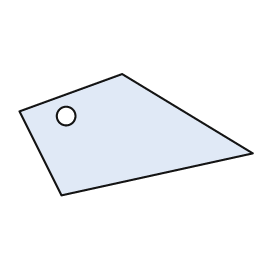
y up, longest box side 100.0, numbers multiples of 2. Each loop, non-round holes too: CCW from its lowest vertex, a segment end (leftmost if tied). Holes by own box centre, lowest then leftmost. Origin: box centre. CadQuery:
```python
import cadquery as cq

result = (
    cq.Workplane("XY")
    .moveTo(-32.0, -26.0)
    .lineTo(50.0, -8.0)
    .lineTo(-6.0, 26.0)
    .lineTo(-50.0, 10.0)
    .close()
    .moveTo(-30.0, 8.0)
    .circle(4.0)
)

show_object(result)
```